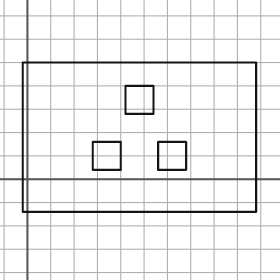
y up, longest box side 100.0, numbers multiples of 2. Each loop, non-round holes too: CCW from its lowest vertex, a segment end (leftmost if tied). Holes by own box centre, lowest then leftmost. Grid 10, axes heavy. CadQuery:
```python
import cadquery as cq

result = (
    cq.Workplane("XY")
    .moveTo(-2.0, -14.0)
    .lineTo(98.0, -14.0)
    .lineTo(98.0, 50.0)
    .lineTo(-2.0, 50.0)
    .close()
    .moveTo(28.0, 4.0)
    .lineTo(40.0, 4.0)
    .lineTo(40.0, 16.0)
    .lineTo(28.0, 16.0)
    .close()
    .moveTo(56.0, 4.0)
    .lineTo(68.0, 4.0)
    .lineTo(68.0, 16.0)
    .lineTo(56.0, 16.0)
    .close()
    .moveTo(42.0, 28.0)
    .lineTo(54.0, 28.0)
    .lineTo(54.0, 40.0)
    .lineTo(42.0, 40.0)
    .close()
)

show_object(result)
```